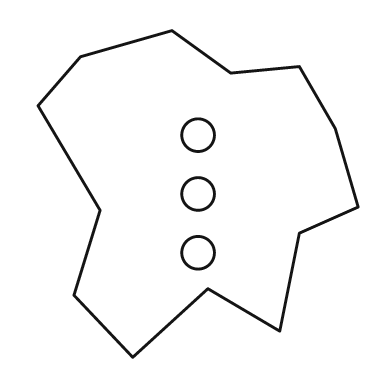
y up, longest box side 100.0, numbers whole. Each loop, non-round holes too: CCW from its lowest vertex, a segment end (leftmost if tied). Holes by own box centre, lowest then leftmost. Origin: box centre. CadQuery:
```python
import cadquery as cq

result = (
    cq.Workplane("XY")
    .moveTo(-20.0, -50.0)
    .lineTo(3.0, -29.0)
    .lineTo(25.0, -42.0)
    .lineTo(31.0, -12.0)
    .lineTo(49.0, -4.0)
    .lineTo(42.0, 20.0)
    .lineTo(31.0, 39.0)
    .lineTo(10.0, 37.0)
    .lineTo(-8.0, 50.0)
    .lineTo(-36.0, 42.0)
    .lineTo(-49.0, 27.0)
    .lineTo(-30.0, -5.0)
    .lineTo(-38.0, -31.0)
    .close()
    .moveTo(0.0, -18.0)
    .circle(5.0)
    .moveTo(0.0, 0.0)
    .circle(5.0)
    .moveTo(0.0, 18.0)
    .circle(5.0)
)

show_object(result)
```